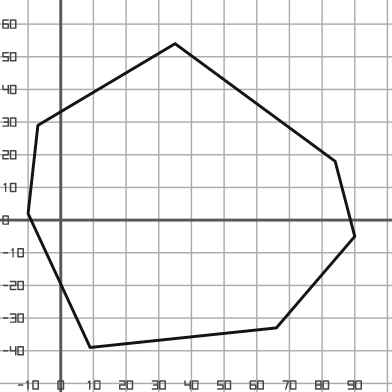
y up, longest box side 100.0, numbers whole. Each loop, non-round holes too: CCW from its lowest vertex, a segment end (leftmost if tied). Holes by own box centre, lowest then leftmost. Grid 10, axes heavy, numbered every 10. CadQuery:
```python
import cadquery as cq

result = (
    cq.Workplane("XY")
    .moveTo(9.0, -39.0)
    .lineTo(66.0, -33.0)
    .lineTo(90.0, -5.0)
    .lineTo(84.0, 18.0)
    .lineTo(35.0, 54.0)
    .lineTo(-7.0, 29.0)
    .lineTo(-10.0, 2.0)
    .close()
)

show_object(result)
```